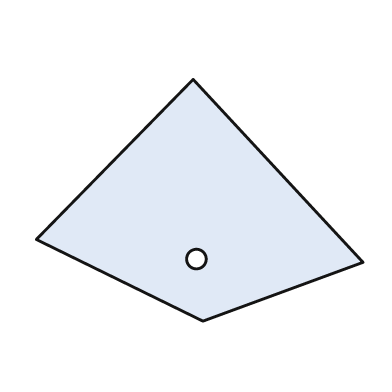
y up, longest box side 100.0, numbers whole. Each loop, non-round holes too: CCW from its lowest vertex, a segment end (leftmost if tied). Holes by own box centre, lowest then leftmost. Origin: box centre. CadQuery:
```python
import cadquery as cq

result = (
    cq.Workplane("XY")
    .moveTo(1.0, -37.0)
    .lineTo(50.0, -19.0)
    .lineTo(-2.0, 37.0)
    .lineTo(-50.0, -12.0)
    .close()
    .moveTo(-1.0, -18.0)
    .circle(3.0)
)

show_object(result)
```